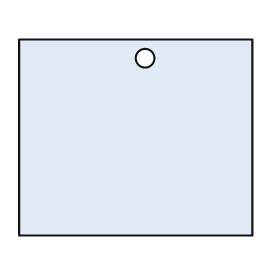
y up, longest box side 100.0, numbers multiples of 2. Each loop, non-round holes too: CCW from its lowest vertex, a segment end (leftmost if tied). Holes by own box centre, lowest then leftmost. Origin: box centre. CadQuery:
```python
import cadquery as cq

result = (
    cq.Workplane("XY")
    .moveTo(-50.0, -42.0)
    .lineTo(50.0, -42.0)
    .lineTo(50.0, 42.0)
    .lineTo(-50.0, 42.0)
    .close()
    .moveTo(4.0, 34.0)
    .circle(4.0)
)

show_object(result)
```